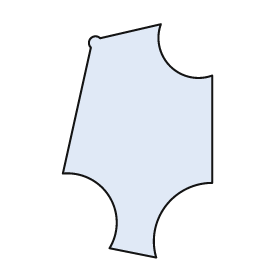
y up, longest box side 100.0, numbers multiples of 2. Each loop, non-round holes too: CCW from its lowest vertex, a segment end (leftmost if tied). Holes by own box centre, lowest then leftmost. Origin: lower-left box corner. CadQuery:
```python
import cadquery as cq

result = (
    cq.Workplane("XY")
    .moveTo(40.0, 0.0)
    .threePointArc((44.0, 22.0), (64.0, 32.0))
    .lineTo(64.0, 78.0)
    .threePointArc((46.0, 82.0), (42.0, 100.0))
    .lineTo(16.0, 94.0)
    .threePointArc((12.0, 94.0), (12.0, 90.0))
    .lineTo(0.0, 36.0)
    .threePointArc((20.0, 26.0), (20.0, 4.0))
    .close()
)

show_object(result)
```